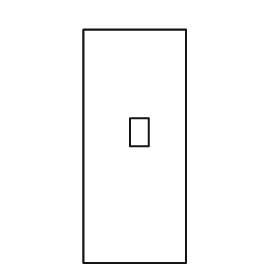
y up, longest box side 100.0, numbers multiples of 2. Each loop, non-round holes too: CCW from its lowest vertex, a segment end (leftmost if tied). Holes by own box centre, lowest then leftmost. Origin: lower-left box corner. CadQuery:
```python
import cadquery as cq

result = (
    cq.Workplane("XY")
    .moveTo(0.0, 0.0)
    .lineTo(44.0, 0.0)
    .lineTo(44.0, 100.0)
    .lineTo(0.0, 100.0)
    .close()
    .moveTo(20.0, 50.0)
    .lineTo(28.0, 50.0)
    .lineTo(28.0, 62.0)
    .lineTo(20.0, 62.0)
    .close()
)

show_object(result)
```